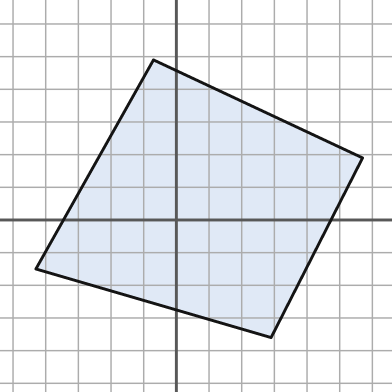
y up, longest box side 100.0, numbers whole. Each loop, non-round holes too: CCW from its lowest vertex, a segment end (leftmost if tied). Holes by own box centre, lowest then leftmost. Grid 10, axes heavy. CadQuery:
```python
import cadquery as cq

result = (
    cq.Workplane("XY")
    .moveTo(29.0, -36.0)
    .lineTo(57.0, 19.0)
    .lineTo(-7.0, 49.0)
    .lineTo(-43.0, -15.0)
    .close()
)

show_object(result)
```